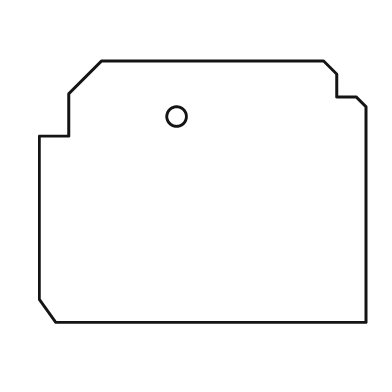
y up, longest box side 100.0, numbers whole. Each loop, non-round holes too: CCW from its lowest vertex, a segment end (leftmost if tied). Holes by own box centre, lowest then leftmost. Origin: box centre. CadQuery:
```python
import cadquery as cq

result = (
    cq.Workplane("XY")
    .moveTo(-45.0, -40.0)
    .lineTo(50.0, -40.0)
    .lineTo(50.0, 26.0)
    .lineTo(47.0, 29.0)
    .lineTo(41.0, 29.0)
    .lineTo(41.0, 36.0)
    .lineTo(37.0, 40.0)
    .lineTo(-31.0, 40.0)
    .lineTo(-41.0, 30.0)
    .lineTo(-41.0, 17.0)
    .lineTo(-50.0, 17.0)
    .lineTo(-50.0, -33.0)
    .close()
    .moveTo(-8.0, 23.0)
    .circle(3.0)
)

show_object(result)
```